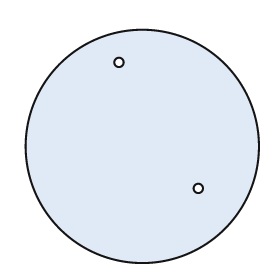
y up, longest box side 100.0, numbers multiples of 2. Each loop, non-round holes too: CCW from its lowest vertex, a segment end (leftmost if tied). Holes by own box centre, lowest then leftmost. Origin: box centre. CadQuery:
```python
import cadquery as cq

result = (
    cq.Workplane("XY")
    .moveTo(0.0, 0.0)
    .circle(50.0)
    .moveTo(24.0, -18.0)
    .circle(2.0)
    .moveTo(-10.0, 36.0)
    .circle(2.0)
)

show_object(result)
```